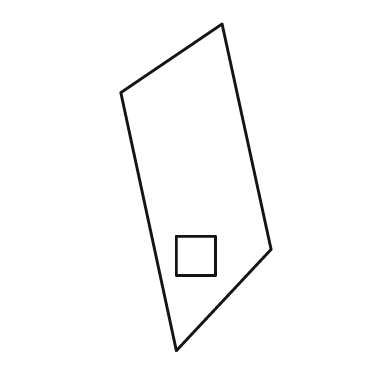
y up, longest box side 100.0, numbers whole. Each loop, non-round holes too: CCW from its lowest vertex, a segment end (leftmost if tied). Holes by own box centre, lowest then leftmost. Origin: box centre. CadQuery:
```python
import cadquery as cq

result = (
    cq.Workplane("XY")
    .moveTo(-6.0, -50.0)
    .lineTo(23.0, -19.0)
    .lineTo(8.0, 50.0)
    .lineTo(-23.0, 29.0)
    .close()
    .moveTo(-6.0, -27.0)
    .lineTo(6.0, -27.0)
    .lineTo(6.0, -15.0)
    .lineTo(-6.0, -15.0)
    .close()
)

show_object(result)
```